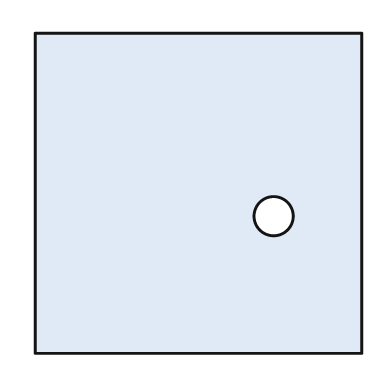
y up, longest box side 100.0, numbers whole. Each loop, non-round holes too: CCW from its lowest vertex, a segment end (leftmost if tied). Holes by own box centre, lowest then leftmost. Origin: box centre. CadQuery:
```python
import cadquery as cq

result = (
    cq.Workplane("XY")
    .moveTo(-50.0, -49.0)
    .lineTo(50.0, -49.0)
    .lineTo(50.0, 49.0)
    .lineTo(-50.0, 49.0)
    .close()
    .moveTo(23.0, -7.0)
    .circle(6.0)
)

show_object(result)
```